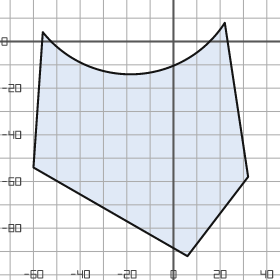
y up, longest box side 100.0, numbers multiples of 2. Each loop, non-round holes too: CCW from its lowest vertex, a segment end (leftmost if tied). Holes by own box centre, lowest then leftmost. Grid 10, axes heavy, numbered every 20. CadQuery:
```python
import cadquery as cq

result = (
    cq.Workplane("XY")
    .moveTo(6.0, -92.0)
    .lineTo(32.0, -58.0)
    .lineTo(22.0, 8.0)
    .threePointArc((-16.0, -14.0), (-56.0, 4.0))
    .lineTo(-60.0, -54.0)
    .close()
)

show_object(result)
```